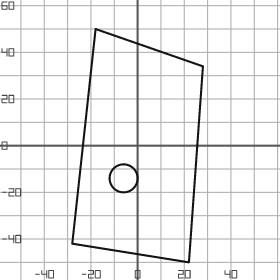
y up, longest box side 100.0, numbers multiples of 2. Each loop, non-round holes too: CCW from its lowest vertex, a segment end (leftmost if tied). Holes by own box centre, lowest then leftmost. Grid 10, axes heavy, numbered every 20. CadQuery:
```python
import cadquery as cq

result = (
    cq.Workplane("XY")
    .moveTo(22.0, -50.0)
    .lineTo(28.0, 34.0)
    .lineTo(-18.0, 50.0)
    .lineTo(-28.0, -42.0)
    .close()
    .moveTo(-6.0, -14.0)
    .circle(6.0)
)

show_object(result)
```